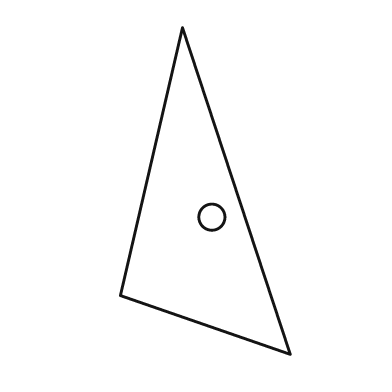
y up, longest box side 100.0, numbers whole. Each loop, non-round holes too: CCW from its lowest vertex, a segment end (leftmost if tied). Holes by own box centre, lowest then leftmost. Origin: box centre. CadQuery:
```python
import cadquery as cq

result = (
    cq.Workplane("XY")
    .moveTo(26.0, -50.0)
    .lineTo(-7.0, 50.0)
    .lineTo(-26.0, -32.0)
    .close()
    .moveTo(2.0, -8.0)
    .circle(4.0)
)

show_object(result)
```